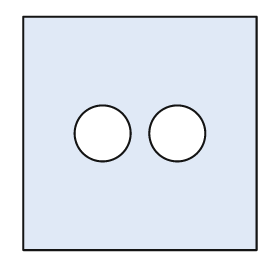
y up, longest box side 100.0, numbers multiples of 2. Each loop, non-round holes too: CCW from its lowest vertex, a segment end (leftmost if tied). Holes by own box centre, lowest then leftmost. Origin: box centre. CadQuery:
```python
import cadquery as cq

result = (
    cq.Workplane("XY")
    .moveTo(-50.0, -50.0)
    .lineTo(50.0, -50.0)
    .lineTo(50.0, 50.0)
    .lineTo(-50.0, 50.0)
    .close()
    .moveTo(-16.0, 0.0)
    .circle(12.0)
    .moveTo(16.0, 0.0)
    .circle(12.0)
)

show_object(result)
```